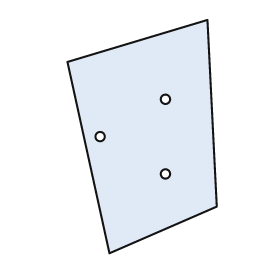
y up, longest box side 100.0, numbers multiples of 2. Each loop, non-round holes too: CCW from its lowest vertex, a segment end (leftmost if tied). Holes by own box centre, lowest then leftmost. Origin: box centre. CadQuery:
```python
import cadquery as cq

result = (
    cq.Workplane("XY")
    .moveTo(-14.0, -50.0)
    .lineTo(32.0, -30.0)
    .lineTo(28.0, 50.0)
    .lineTo(-32.0, 32.0)
    .close()
    .moveTo(10.0, -16.0)
    .circle(2.0)
    .moveTo(-18.0, 0.0)
    .circle(2.0)
    .moveTo(10.0, 16.0)
    .circle(2.0)
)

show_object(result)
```